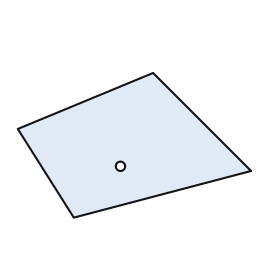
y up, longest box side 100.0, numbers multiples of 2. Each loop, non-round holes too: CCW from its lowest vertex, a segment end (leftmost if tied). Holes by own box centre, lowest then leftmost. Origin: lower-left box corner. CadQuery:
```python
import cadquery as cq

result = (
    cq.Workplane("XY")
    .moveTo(24.0, 0.0)
    .lineTo(100.0, 20.0)
    .lineTo(58.0, 62.0)
    .lineTo(0.0, 38.0)
    .close()
    .moveTo(44.0, 22.0)
    .circle(2.0)
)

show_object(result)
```